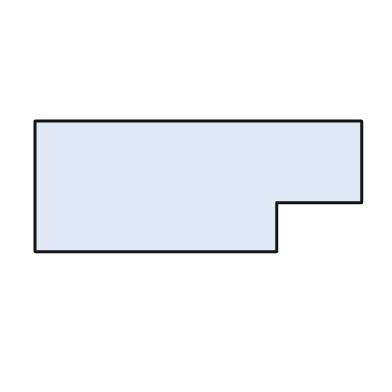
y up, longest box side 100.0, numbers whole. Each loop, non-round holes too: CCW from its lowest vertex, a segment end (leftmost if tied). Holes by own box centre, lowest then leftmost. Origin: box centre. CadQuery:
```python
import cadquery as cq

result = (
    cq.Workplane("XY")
    .moveTo(-50.0, -20.0)
    .lineTo(24.0, -20.0)
    .lineTo(24.0, -5.0)
    .lineTo(50.0, -5.0)
    .lineTo(50.0, 20.0)
    .lineTo(-50.0, 20.0)
    .close()
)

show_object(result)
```